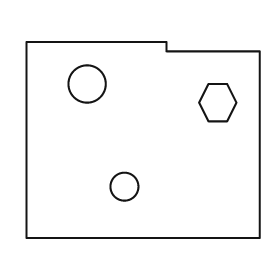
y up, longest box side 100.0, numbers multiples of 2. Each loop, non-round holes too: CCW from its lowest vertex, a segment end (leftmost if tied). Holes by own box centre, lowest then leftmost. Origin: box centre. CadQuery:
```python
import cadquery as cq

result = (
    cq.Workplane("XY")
    .moveTo(-50.0, -42.0)
    .lineTo(50.0, -42.0)
    .lineTo(50.0, 38.0)
    .lineTo(10.0, 38.0)
    .lineTo(10.0, 42.0)
    .lineTo(-50.0, 42.0)
    .close()
    .moveTo(-8.0, -20.0)
    .circle(6.0)
    .moveTo(28.0, 8.0)
    .lineTo(36.0, 8.0)
    .lineTo(40.0, 16.0)
    .lineTo(36.0, 24.0)
    .lineTo(28.0, 24.0)
    .lineTo(24.0, 16.0)
    .close()
    .moveTo(-24.0, 24.0)
    .circle(8.0)
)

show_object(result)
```